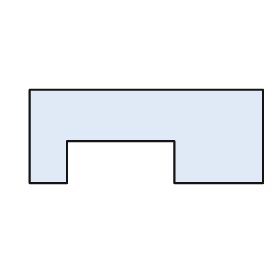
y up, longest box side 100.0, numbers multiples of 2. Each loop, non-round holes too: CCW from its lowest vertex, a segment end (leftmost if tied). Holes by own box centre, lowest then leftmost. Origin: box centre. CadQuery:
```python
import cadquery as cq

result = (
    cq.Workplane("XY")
    .moveTo(-50.0, -20.0)
    .lineTo(-34.0, -20.0)
    .lineTo(-34.0, -2.0)
    .lineTo(12.0, -2.0)
    .lineTo(12.0, -20.0)
    .lineTo(50.0, -20.0)
    .lineTo(50.0, 20.0)
    .lineTo(-50.0, 20.0)
    .close()
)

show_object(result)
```